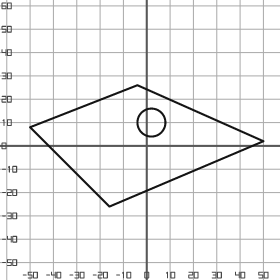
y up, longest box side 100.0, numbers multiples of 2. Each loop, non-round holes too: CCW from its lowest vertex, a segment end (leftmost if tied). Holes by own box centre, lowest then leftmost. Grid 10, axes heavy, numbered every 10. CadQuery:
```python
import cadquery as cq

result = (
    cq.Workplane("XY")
    .moveTo(-16.0, -26.0)
    .lineTo(50.0, 2.0)
    .lineTo(-4.0, 26.0)
    .lineTo(-50.0, 8.0)
    .close()
    .moveTo(2.0, 10.0)
    .circle(6.0)
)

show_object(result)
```